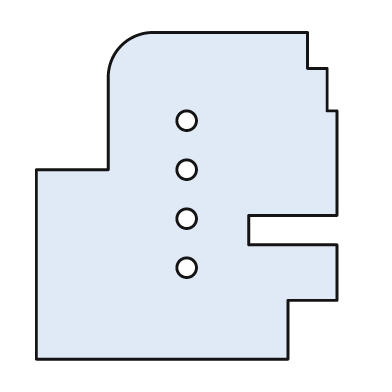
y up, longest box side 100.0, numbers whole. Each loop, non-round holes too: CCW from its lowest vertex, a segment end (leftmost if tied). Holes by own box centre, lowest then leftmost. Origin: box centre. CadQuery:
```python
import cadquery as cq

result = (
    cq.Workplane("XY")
    .moveTo(-46.0, -50.0)
    .lineTo(31.0, -50.0)
    .lineTo(31.0, -32.0)
    .lineTo(46.0, -32.0)
    .lineTo(46.0, -15.0)
    .lineTo(19.0, -15.0)
    .lineTo(19.0, -6.0)
    .lineTo(46.0, -6.0)
    .lineTo(46.0, 26.0)
    .lineTo(43.0, 26.0)
    .lineTo(43.0, 39.0)
    .lineTo(37.0, 39.0)
    .lineTo(37.0, 50.0)
    .lineTo(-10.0, 50.0)
    .threePointArc((-20.0, 46.0), (-24.0, 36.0))
    .lineTo(-24.0, 8.0)
    .lineTo(-46.0, 8.0)
    .close()
    .moveTo(0.0, -22.0)
    .circle(3.0)
    .moveTo(0.0, -7.0)
    .circle(3.0)
    .moveTo(0.0, 8.0)
    .circle(3.0)
    .moveTo(0.0, 23.0)
    .circle(3.0)
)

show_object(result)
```